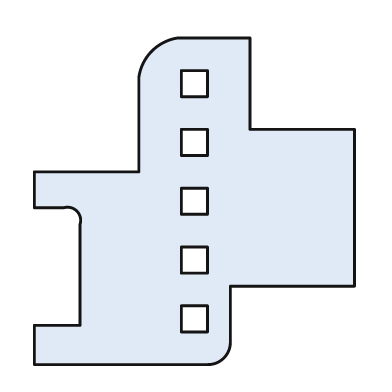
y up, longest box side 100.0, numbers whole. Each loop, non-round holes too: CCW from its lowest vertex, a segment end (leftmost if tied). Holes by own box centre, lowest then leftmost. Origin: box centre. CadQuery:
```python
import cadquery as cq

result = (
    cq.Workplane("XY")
    .moveTo(-49.0, -50.0)
    .lineTo(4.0, -50.0)
    .threePointArc((9.0, -48.0), (11.0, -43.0))
    .lineTo(11.0, -26.0)
    .lineTo(49.0, -26.0)
    .lineTo(49.0, 22.0)
    .lineTo(17.0, 22.0)
    .lineTo(17.0, 50.0)
    .lineTo(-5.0, 50.0)
    .threePointArc((-13.0, 46.0), (-17.0, 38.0))
    .lineTo(-17.0, 9.0)
    .lineTo(-49.0, 9.0)
    .lineTo(-49.0, -2.0)
    .lineTo(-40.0, -2.0)
    .threePointArc((-36.0, -3.0), (-35.0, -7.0))
    .lineTo(-35.0, -38.0)
    .lineTo(-49.0, -38.0)
    .close()
    .moveTo(-4.0, -40.0)
    .lineTo(4.0, -40.0)
    .lineTo(4.0, -32.0)
    .lineTo(-4.0, -32.0)
    .close()
    .moveTo(-4.0, -22.0)
    .lineTo(4.0, -22.0)
    .lineTo(4.0, -14.0)
    .lineTo(-4.0, -14.0)
    .close()
    .moveTo(-4.0, -4.0)
    .lineTo(4.0, -4.0)
    .lineTo(4.0, 4.0)
    .lineTo(-4.0, 4.0)
    .close()
    .moveTo(-4.0, 14.0)
    .lineTo(4.0, 14.0)
    .lineTo(4.0, 22.0)
    .lineTo(-4.0, 22.0)
    .close()
    .moveTo(-4.0, 32.0)
    .lineTo(4.0, 32.0)
    .lineTo(4.0, 40.0)
    .lineTo(-4.0, 40.0)
    .close()
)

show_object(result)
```